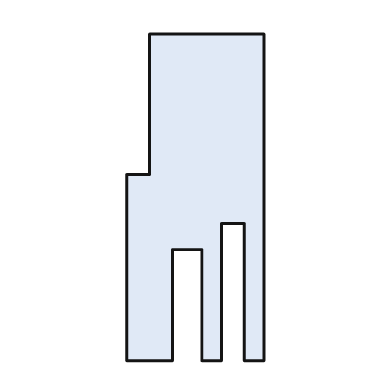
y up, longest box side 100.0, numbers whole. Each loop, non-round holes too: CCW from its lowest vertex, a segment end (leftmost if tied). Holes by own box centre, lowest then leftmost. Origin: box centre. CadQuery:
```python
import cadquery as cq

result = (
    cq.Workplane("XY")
    .moveTo(-21.0, -50.0)
    .lineTo(-7.0, -50.0)
    .lineTo(-7.0, -16.0)
    .lineTo(2.0, -16.0)
    .lineTo(2.0, -50.0)
    .lineTo(8.0, -50.0)
    .lineTo(8.0, -8.0)
    .lineTo(15.0, -8.0)
    .lineTo(15.0, -50.0)
    .lineTo(21.0, -50.0)
    .lineTo(21.0, 50.0)
    .lineTo(-14.0, 50.0)
    .lineTo(-14.0, 7.0)
    .lineTo(-21.0, 7.0)
    .close()
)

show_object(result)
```